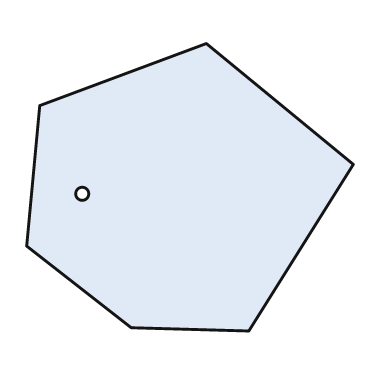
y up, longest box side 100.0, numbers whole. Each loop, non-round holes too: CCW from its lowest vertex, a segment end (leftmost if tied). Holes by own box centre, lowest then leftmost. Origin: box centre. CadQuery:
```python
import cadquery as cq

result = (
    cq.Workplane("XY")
    .moveTo(18.0, -44.0)
    .lineTo(50.0, 7.0)
    .lineTo(5.0, 44.0)
    .lineTo(-46.0, 25.0)
    .lineTo(-50.0, -18.0)
    .lineTo(-18.0, -43.0)
    .close()
    .moveTo(-33.0, -2.0)
    .circle(2.0)
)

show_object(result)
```